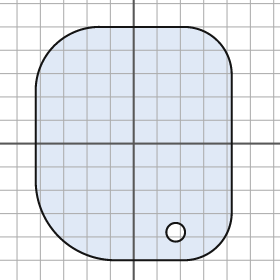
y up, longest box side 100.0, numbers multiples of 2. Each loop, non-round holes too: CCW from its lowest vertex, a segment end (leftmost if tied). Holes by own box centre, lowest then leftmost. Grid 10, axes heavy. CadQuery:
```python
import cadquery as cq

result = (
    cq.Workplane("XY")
    .moveTo(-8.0, -50.0)
    .lineTo(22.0, -50.0)
    .threePointArc((36.0, -44.0), (42.0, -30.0))
    .lineTo(42.0, 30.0)
    .threePointArc((36.0, 44.0), (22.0, 50.0))
    .lineTo(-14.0, 50.0)
    .threePointArc((-34.0, 42.0), (-42.0, 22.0))
    .lineTo(-42.0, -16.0)
    .threePointArc((-32.0, -40.0), (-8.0, -50.0))
    .close()
    .moveTo(18.0, -38.0)
    .circle(4.0)
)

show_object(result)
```